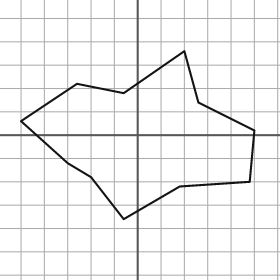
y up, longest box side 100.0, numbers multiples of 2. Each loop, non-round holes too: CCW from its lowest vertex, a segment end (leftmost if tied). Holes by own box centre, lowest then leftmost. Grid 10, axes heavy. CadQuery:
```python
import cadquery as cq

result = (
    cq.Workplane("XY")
    .moveTo(-6.0, -36.0)
    .lineTo(18.0, -22.0)
    .lineTo(48.0, -20.0)
    .lineTo(50.0, 2.0)
    .lineTo(26.0, 14.0)
    .lineTo(20.0, 36.0)
    .lineTo(-6.0, 18.0)
    .lineTo(-26.0, 22.0)
    .lineTo(-50.0, 6.0)
    .lineTo(-30.0, -12.0)
    .lineTo(-20.0, -18.0)
    .close()
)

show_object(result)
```